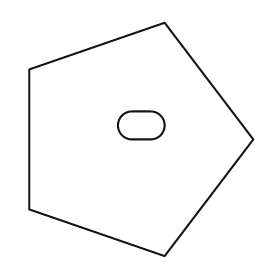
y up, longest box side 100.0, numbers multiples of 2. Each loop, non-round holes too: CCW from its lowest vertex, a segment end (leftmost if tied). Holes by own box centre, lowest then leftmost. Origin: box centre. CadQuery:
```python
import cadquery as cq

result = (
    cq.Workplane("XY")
    .moveTo(10.0, -50.0)
    .lineTo(48.0, 0.0)
    .lineTo(10.0, 50.0)
    .lineTo(-48.0, 30.0)
    .lineTo(-48.0, -30.0)
    .close()
    .moveTo(-4.0, 0.0)
    .lineTo(4.0, 0.0)
    .threePointArc((10.0, 6.0), (4.0, 12.0))
    .lineTo(-4.0, 12.0)
    .threePointArc((-10.0, 6.0), (-4.0, 0.0))
    .close()
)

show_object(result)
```